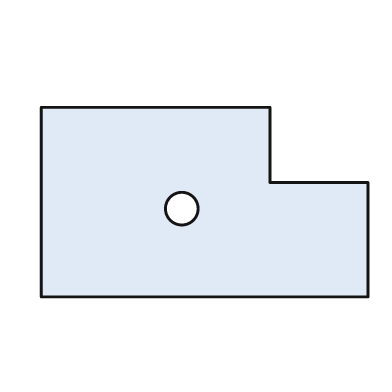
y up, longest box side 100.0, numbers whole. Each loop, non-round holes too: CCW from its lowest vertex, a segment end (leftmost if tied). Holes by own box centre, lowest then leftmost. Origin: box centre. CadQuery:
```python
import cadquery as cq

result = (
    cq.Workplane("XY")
    .moveTo(-50.0, -29.0)
    .lineTo(50.0, -29.0)
    .lineTo(50.0, 6.0)
    .lineTo(20.0, 6.0)
    .lineTo(20.0, 29.0)
    .lineTo(-50.0, 29.0)
    .close()
    .moveTo(-7.0, -2.0)
    .circle(5.0)
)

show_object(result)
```